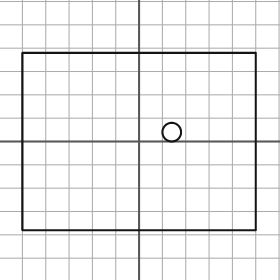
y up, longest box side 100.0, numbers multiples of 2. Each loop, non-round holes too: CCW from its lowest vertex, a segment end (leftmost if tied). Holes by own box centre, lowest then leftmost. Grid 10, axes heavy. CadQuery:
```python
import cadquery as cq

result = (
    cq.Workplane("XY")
    .moveTo(-50.0, -38.0)
    .lineTo(50.0, -38.0)
    .lineTo(50.0, 38.0)
    .lineTo(-50.0, 38.0)
    .close()
    .moveTo(14.0, 4.0)
    .circle(4.0)
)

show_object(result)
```